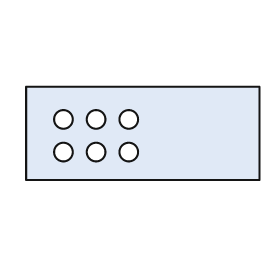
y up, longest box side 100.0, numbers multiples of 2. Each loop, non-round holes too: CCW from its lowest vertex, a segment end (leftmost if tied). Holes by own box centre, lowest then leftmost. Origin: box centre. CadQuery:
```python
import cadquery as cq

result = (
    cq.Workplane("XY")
    .moveTo(-50.0, -20.0)
    .lineTo(50.0, -20.0)
    .lineTo(50.0, 20.0)
    .lineTo(-50.0, 20.0)
    .close()
    .moveTo(-34.0, -8.0)
    .circle(4.0)
    .moveTo(-20.0, -8.0)
    .circle(4.0)
    .moveTo(-6.0, -8.0)
    .circle(4.0)
    .moveTo(-34.0, 6.0)
    .circle(4.0)
    .moveTo(-20.0, 6.0)
    .circle(4.0)
    .moveTo(-6.0, 6.0)
    .circle(4.0)
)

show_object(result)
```